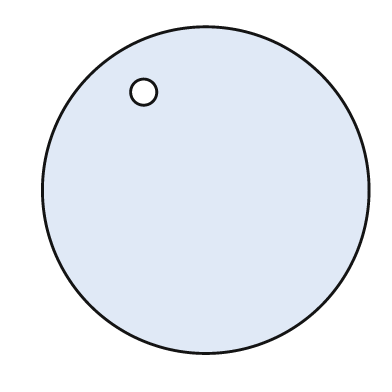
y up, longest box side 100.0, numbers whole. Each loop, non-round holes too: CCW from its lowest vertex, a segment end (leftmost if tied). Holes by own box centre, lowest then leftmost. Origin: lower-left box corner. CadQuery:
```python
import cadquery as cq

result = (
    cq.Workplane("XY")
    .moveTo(50.0, 50.0)
    .circle(50.0)
    .moveTo(31.0, 80.0)
    .circle(4.0)
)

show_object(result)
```